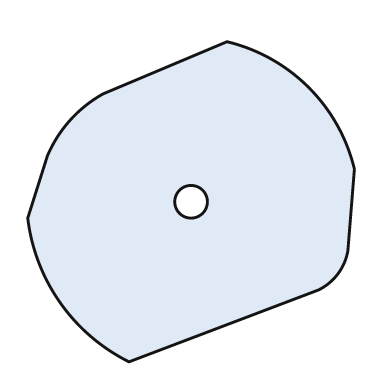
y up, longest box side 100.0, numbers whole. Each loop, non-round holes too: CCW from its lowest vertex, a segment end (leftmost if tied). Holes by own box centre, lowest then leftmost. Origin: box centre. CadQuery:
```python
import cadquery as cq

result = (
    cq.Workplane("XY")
    .moveTo(-19.0, -49.0)
    .lineTo(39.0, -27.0)
    .threePointArc((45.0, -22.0), (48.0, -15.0))
    .lineTo(50.0, 10.0)
    .threePointArc((36.0, 35.0), (11.0, 49.0))
    .lineTo(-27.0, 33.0)
    .threePointArc((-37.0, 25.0), (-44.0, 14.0))
    .lineTo(-50.0, -5.0)
    .threePointArc((-40.0, -31.0), (-19.0, -49.0))
    .close()
    .moveTo(0.0, 0.0)
    .circle(5.0)
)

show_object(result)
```